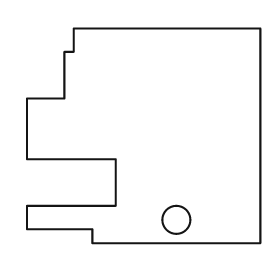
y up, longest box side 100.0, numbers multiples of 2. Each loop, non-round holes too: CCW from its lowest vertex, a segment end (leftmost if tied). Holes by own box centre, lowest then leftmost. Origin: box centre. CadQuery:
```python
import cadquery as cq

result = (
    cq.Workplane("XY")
    .moveTo(-22.0, -46.0)
    .lineTo(50.0, -46.0)
    .lineTo(50.0, 46.0)
    .lineTo(-30.0, 46.0)
    .lineTo(-30.0, 36.0)
    .lineTo(-34.0, 36.0)
    .lineTo(-34.0, 16.0)
    .lineTo(-50.0, 16.0)
    .lineTo(-50.0, -10.0)
    .lineTo(-12.0, -10.0)
    .lineTo(-12.0, -30.0)
    .lineTo(-50.0, -30.0)
    .lineTo(-50.0, -40.0)
    .lineTo(-22.0, -40.0)
    .close()
    .moveTo(14.0, -36.0)
    .circle(6.0)
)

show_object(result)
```